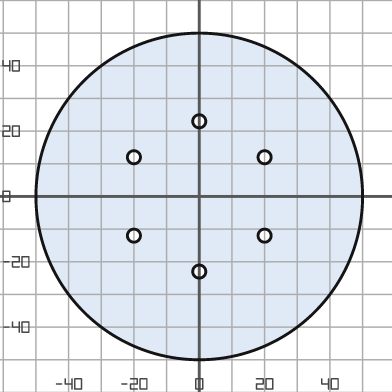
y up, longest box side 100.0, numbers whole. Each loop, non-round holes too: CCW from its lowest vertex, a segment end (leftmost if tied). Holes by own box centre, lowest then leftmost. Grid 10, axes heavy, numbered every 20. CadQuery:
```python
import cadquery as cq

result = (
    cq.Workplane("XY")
    .moveTo(0.0, 0.0)
    .circle(50.0)
    .moveTo(0.0, -23.0)
    .circle(2.0)
    .moveTo(-20.0, -12.0)
    .circle(2.0)
    .moveTo(20.0, -12.0)
    .circle(2.0)
    .moveTo(-20.0, 12.0)
    .circle(2.0)
    .moveTo(20.0, 12.0)
    .circle(2.0)
    .moveTo(0.0, 23.0)
    .circle(2.0)
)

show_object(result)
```